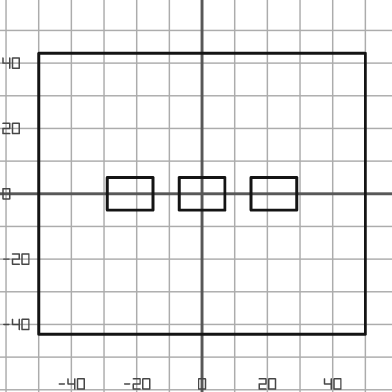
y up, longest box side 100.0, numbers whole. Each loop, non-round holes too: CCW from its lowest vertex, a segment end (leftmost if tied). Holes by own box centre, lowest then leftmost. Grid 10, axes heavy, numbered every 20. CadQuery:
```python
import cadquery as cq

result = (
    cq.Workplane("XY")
    .moveTo(-50.0, -43.0)
    .lineTo(50.0, -43.0)
    .lineTo(50.0, 43.0)
    .lineTo(-50.0, 43.0)
    .close()
    .moveTo(-29.0, -5.0)
    .lineTo(-15.0, -5.0)
    .lineTo(-15.0, 5.0)
    .lineTo(-29.0, 5.0)
    .close()
    .moveTo(-7.0, -5.0)
    .lineTo(7.0, -5.0)
    .lineTo(7.0, 5.0)
    .lineTo(-7.0, 5.0)
    .close()
    .moveTo(15.0, -5.0)
    .lineTo(29.0, -5.0)
    .lineTo(29.0, 5.0)
    .lineTo(15.0, 5.0)
    .close()
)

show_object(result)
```